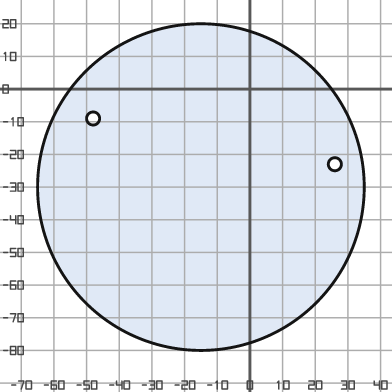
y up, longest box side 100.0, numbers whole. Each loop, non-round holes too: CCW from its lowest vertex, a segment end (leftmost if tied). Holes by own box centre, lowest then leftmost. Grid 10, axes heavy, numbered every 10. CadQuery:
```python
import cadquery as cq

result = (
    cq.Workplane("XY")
    .moveTo(-15.0, -30.0)
    .circle(50.0)
    .moveTo(26.0, -23.0)
    .circle(2.0)
    .moveTo(-48.0, -9.0)
    .circle(2.0)
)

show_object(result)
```